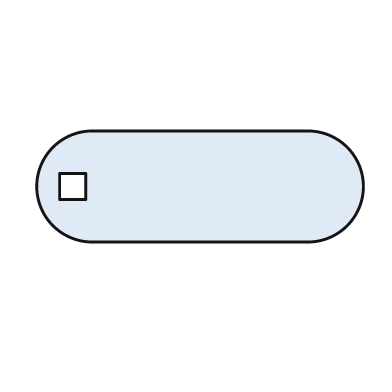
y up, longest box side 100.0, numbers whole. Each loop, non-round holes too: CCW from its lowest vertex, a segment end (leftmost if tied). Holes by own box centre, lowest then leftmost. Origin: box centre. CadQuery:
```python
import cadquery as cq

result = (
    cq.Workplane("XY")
    .moveTo(-33.0, -17.0)
    .lineTo(33.0, -17.0)
    .threePointArc((50.0, 0.0), (33.0, 17.0))
    .lineTo(-33.0, 17.0)
    .threePointArc((-50.0, 0.0), (-33.0, -17.0))
    .close()
    .moveTo(-43.0, -4.0)
    .lineTo(-35.0, -4.0)
    .lineTo(-35.0, 4.0)
    .lineTo(-43.0, 4.0)
    .close()
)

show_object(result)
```